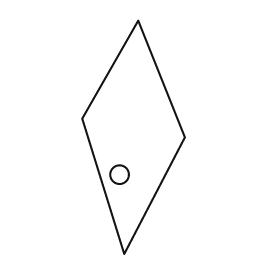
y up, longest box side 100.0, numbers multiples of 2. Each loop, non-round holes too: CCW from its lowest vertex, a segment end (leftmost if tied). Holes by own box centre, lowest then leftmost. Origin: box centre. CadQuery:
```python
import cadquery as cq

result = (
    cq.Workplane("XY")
    .moveTo(-4.0, -50.0)
    .lineTo(22.0, 0.0)
    .lineTo(2.0, 50.0)
    .lineTo(-22.0, 8.0)
    .close()
    .moveTo(-6.0, -16.0)
    .circle(4.0)
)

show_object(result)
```